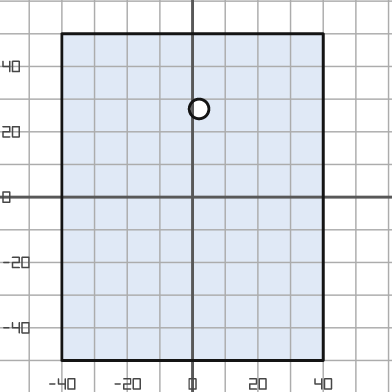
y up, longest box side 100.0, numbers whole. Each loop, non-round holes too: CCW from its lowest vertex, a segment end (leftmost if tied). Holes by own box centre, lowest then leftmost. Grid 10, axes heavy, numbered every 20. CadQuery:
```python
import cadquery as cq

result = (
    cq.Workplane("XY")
    .moveTo(-40.0, -50.0)
    .lineTo(40.0, -50.0)
    .lineTo(40.0, 50.0)
    .lineTo(-40.0, 50.0)
    .close()
    .moveTo(2.0, 27.0)
    .circle(3.0)
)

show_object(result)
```